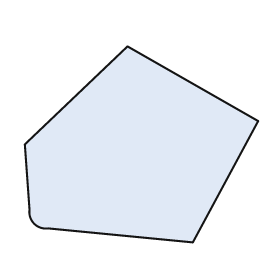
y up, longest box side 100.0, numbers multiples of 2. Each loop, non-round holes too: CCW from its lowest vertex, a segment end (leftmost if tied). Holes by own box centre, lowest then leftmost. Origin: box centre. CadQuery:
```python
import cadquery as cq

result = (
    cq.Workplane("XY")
    .moveTo(22.0, -42.0)
    .lineTo(50.0, 10.0)
    .lineTo(-6.0, 42.0)
    .lineTo(-50.0, 0.0)
    .lineTo(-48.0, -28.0)
    .threePointArc((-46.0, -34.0), (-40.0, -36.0))
    .close()
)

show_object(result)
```